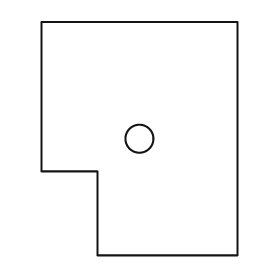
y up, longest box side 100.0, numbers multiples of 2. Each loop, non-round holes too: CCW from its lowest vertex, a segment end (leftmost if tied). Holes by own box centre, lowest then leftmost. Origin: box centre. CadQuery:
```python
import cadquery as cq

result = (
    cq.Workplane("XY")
    .moveTo(-18.0, -50.0)
    .lineTo(42.0, -50.0)
    .lineTo(42.0, 50.0)
    .lineTo(-42.0, 50.0)
    .lineTo(-42.0, -14.0)
    .lineTo(-18.0, -14.0)
    .close()
    .moveTo(0.0, 0.0)
    .circle(6.0)
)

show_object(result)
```